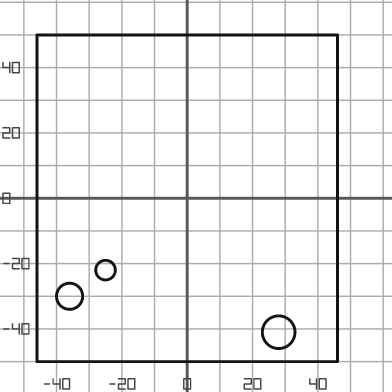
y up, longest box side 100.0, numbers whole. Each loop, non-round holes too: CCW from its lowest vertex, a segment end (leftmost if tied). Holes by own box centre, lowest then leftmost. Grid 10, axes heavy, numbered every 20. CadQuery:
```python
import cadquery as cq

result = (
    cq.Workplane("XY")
    .moveTo(-46.0, -50.0)
    .lineTo(46.0, -50.0)
    .lineTo(46.0, 50.0)
    .lineTo(-46.0, 50.0)
    .close()
    .moveTo(28.0, -41.0)
    .circle(5.0)
    .moveTo(-36.0, -30.0)
    .circle(4.0)
    .moveTo(-25.0, -22.0)
    .circle(3.0)
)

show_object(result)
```